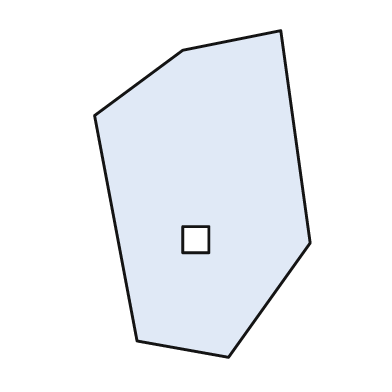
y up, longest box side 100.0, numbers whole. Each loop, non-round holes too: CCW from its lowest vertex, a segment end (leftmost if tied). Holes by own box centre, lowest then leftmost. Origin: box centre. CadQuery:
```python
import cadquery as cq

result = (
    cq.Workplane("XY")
    .moveTo(8.0, -50.0)
    .lineTo(33.0, -15.0)
    .lineTo(24.0, 50.0)
    .lineTo(-6.0, 44.0)
    .lineTo(-33.0, 24.0)
    .lineTo(-20.0, -45.0)
    .close()
    .moveTo(-6.0, -18.0)
    .lineTo(2.0, -18.0)
    .lineTo(2.0, -10.0)
    .lineTo(-6.0, -10.0)
    .close()
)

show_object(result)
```